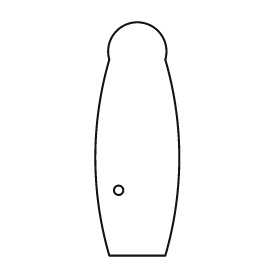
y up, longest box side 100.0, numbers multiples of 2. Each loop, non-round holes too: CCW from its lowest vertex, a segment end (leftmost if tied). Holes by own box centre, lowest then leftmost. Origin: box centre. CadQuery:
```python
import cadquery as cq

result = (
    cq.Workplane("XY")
    .moveTo(-12.0, -50.0)
    .lineTo(12.0, -50.0)
    .threePointArc((18.0, -8.0), (12.0, 34.0))
    .threePointArc((0.0, 50.0), (-12.0, 34.0))
    .threePointArc((-18.0, -8.0), (-12.0, -50.0))
    .close()
    .moveTo(-8.0, -22.0)
    .circle(2.0)
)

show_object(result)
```